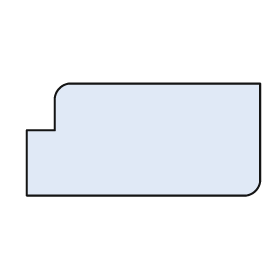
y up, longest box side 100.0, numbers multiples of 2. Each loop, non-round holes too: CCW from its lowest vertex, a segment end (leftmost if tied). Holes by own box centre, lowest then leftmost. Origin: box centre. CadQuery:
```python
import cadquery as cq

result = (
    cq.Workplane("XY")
    .moveTo(-50.0, -24.0)
    .lineTo(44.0, -24.0)
    .threePointArc((48.0, -22.0), (50.0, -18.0))
    .lineTo(50.0, 24.0)
    .lineTo(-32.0, 24.0)
    .threePointArc((-36.0, 22.0), (-38.0, 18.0))
    .lineTo(-38.0, 4.0)
    .lineTo(-50.0, 4.0)
    .close()
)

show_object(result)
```